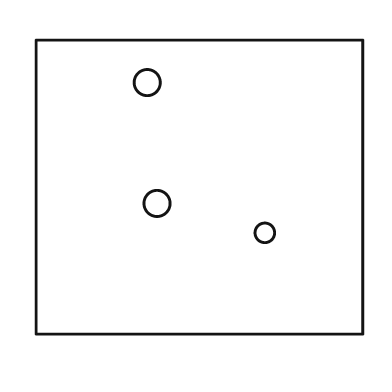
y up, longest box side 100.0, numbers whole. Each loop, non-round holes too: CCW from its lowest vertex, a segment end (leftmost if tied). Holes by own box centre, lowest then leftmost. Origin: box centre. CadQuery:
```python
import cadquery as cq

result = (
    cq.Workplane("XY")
    .moveTo(-50.0, -45.0)
    .lineTo(50.0, -45.0)
    .lineTo(50.0, 45.0)
    .lineTo(-50.0, 45.0)
    .close()
    .moveTo(20.0, -14.0)
    .circle(3.0)
    .moveTo(-13.0, -5.0)
    .circle(4.0)
    .moveTo(-16.0, 32.0)
    .circle(4.0)
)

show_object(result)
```